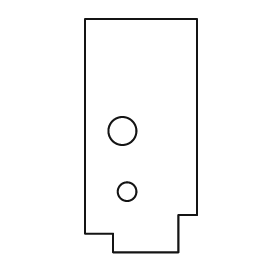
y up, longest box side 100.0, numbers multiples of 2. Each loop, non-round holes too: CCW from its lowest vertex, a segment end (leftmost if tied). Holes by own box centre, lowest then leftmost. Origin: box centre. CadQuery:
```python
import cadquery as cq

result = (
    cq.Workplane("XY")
    .moveTo(-12.0, -50.0)
    .lineTo(16.0, -50.0)
    .lineTo(16.0, -34.0)
    .lineTo(24.0, -34.0)
    .lineTo(24.0, 50.0)
    .lineTo(-24.0, 50.0)
    .lineTo(-24.0, -42.0)
    .lineTo(-12.0, -42.0)
    .close()
    .moveTo(-6.0, -24.0)
    .circle(4.0)
    .moveTo(-8.0, 2.0)
    .circle(6.0)
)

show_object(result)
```